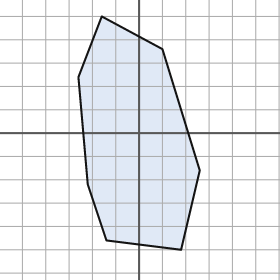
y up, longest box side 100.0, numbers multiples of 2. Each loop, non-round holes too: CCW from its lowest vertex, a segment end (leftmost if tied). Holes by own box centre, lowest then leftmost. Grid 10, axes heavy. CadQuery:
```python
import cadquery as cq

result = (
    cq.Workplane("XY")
    .moveTo(18.0, -50.0)
    .lineTo(26.0, -16.0)
    .lineTo(10.0, 36.0)
    .lineTo(-16.0, 50.0)
    .lineTo(-26.0, 24.0)
    .lineTo(-22.0, -22.0)
    .lineTo(-14.0, -46.0)
    .close()
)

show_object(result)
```